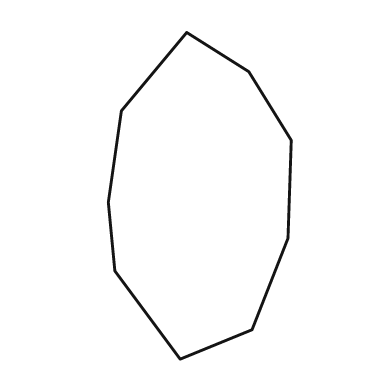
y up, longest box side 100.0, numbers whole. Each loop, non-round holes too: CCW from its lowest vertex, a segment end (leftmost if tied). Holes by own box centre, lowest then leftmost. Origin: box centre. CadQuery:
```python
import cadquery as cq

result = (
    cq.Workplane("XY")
    .moveTo(-6.0, -50.0)
    .lineTo(16.0, -41.0)
    .lineTo(27.0, -13.0)
    .lineTo(28.0, 17.0)
    .lineTo(15.0, 38.0)
    .lineTo(-4.0, 50.0)
    .lineTo(-24.0, 26.0)
    .lineTo(-28.0, -2.0)
    .lineTo(-26.0, -23.0)
    .close()
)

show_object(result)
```